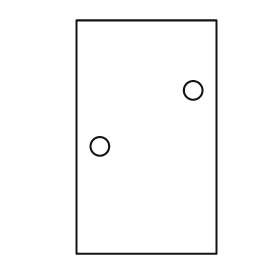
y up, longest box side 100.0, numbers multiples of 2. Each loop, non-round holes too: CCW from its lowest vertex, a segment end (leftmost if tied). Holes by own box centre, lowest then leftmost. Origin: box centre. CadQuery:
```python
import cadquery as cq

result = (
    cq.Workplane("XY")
    .moveTo(-30.0, -50.0)
    .lineTo(30.0, -50.0)
    .lineTo(30.0, 50.0)
    .lineTo(-30.0, 50.0)
    .close()
    .moveTo(-20.0, -4.0)
    .circle(4.0)
    .moveTo(20.0, 20.0)
    .circle(4.0)
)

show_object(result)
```